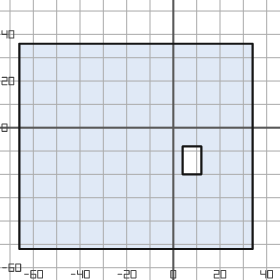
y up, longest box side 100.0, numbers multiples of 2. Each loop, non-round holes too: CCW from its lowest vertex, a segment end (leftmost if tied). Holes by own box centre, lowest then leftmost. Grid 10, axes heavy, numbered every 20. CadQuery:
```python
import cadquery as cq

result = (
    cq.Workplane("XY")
    .moveTo(-66.0, -52.0)
    .lineTo(34.0, -52.0)
    .lineTo(34.0, 36.0)
    .lineTo(-66.0, 36.0)
    .close()
    .moveTo(4.0, -20.0)
    .lineTo(12.0, -20.0)
    .lineTo(12.0, -8.0)
    .lineTo(4.0, -8.0)
    .close()
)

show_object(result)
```